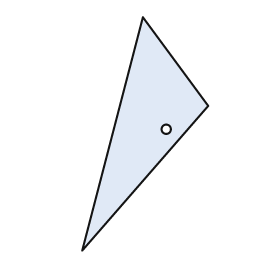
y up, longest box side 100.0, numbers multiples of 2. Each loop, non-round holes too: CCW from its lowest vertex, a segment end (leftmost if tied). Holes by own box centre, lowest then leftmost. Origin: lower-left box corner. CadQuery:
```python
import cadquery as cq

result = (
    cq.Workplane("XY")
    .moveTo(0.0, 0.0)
    .lineTo(54.0, 62.0)
    .lineTo(26.0, 100.0)
    .close()
    .moveTo(36.0, 52.0)
    .circle(2.0)
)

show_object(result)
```